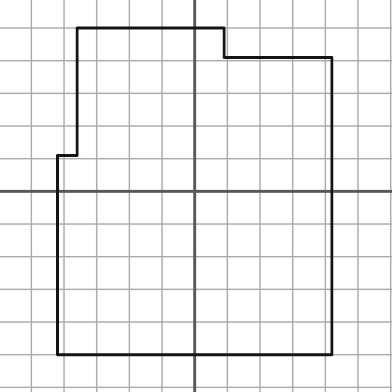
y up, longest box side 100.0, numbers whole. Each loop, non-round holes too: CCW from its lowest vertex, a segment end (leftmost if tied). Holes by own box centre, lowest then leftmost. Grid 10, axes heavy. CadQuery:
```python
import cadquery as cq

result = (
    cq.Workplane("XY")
    .moveTo(-42.0, -50.0)
    .lineTo(42.0, -50.0)
    .lineTo(42.0, 41.0)
    .lineTo(9.0, 41.0)
    .lineTo(9.0, 50.0)
    .lineTo(-36.0, 50.0)
    .lineTo(-36.0, 11.0)
    .lineTo(-42.0, 11.0)
    .close()
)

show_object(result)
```